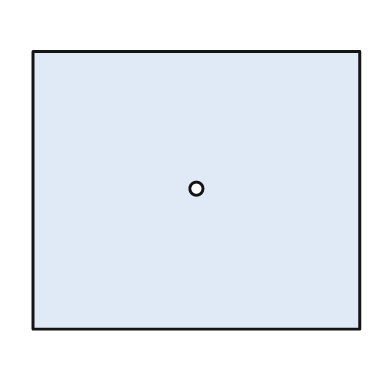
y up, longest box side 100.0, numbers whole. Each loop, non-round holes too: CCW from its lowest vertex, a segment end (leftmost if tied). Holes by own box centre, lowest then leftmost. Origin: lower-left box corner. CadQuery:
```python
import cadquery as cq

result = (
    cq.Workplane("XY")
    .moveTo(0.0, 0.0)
    .lineTo(100.0, 0.0)
    .lineTo(100.0, 85.0)
    .lineTo(0.0, 85.0)
    .close()
    .moveTo(50.0, 43.0)
    .circle(2.0)
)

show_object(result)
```